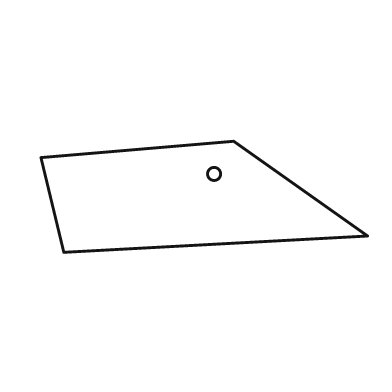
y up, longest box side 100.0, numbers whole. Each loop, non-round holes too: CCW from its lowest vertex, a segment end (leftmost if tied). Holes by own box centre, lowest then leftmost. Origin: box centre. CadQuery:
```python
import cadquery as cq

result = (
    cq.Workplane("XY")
    .moveTo(-43.0, -17.0)
    .lineTo(50.0, -12.0)
    .lineTo(9.0, 17.0)
    .lineTo(-50.0, 12.0)
    .close()
    .moveTo(3.0, 7.0)
    .circle(2.0)
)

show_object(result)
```